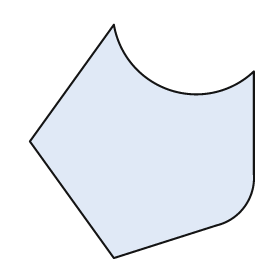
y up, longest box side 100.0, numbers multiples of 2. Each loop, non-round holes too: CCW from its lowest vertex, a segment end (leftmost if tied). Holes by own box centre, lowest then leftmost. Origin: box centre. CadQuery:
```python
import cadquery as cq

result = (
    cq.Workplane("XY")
    .moveTo(-12.0, -50.0)
    .lineTo(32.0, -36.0)
    .threePointArc((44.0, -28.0), (48.0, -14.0))
    .lineTo(48.0, 30.0)
    .threePointArc((12.0, 22.0), (-12.0, 50.0))
    .lineTo(-48.0, 0.0)
    .close()
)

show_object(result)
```